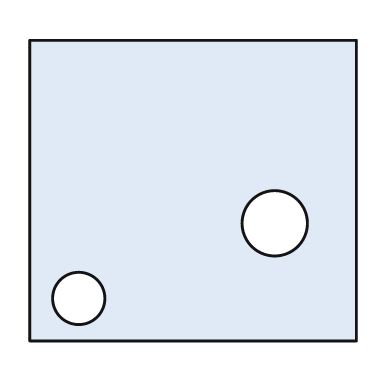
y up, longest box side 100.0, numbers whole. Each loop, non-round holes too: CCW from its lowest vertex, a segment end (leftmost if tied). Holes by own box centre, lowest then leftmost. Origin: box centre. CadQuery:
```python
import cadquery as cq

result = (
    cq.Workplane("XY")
    .moveTo(-50.0, -46.0)
    .lineTo(50.0, -46.0)
    .lineTo(50.0, 46.0)
    .lineTo(-50.0, 46.0)
    .close()
    .moveTo(-35.0, -33.0)
    .circle(8.0)
    .moveTo(25.0, -10.0)
    .circle(10.0)
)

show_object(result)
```